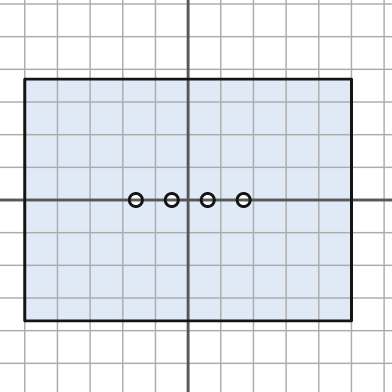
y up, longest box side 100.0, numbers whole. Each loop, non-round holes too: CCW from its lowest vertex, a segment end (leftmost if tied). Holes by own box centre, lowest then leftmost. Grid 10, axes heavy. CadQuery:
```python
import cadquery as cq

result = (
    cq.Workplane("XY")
    .moveTo(-50.0, -37.0)
    .lineTo(50.0, -37.0)
    .lineTo(50.0, 37.0)
    .lineTo(-50.0, 37.0)
    .close()
    .moveTo(-16.0, 0.0)
    .circle(2.0)
    .moveTo(-5.0, 0.0)
    .circle(2.0)
    .moveTo(6.0, 0.0)
    .circle(2.0)
    .moveTo(17.0, 0.0)
    .circle(2.0)
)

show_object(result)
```